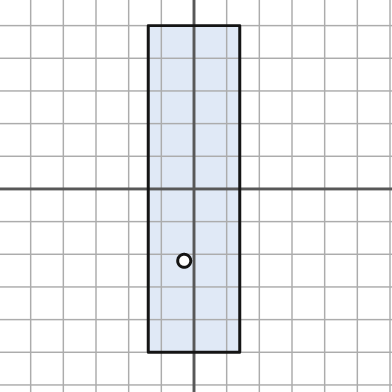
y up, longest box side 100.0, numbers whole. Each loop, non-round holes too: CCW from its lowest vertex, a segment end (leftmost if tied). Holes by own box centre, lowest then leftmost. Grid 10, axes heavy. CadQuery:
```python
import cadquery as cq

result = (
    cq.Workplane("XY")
    .moveTo(-14.0, -50.0)
    .lineTo(14.0, -50.0)
    .lineTo(14.0, 50.0)
    .lineTo(-14.0, 50.0)
    .close()
    .moveTo(-3.0, -22.0)
    .circle(2.0)
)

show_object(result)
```